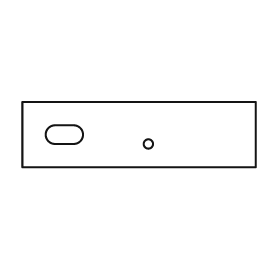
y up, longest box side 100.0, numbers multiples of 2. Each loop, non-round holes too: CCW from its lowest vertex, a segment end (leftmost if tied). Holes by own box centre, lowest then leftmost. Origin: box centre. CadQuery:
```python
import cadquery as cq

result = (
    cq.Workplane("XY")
    .moveTo(-50.0, -14.0)
    .lineTo(50.0, -14.0)
    .lineTo(50.0, 14.0)
    .lineTo(-50.0, 14.0)
    .close()
    .moveTo(4.0, -4.0)
    .circle(2.0)
    .moveTo(-36.0, -4.0)
    .lineTo(-28.0, -4.0)
    .threePointArc((-24.0, 0.0), (-28.0, 4.0))
    .lineTo(-36.0, 4.0)
    .threePointArc((-40.0, 0.0), (-36.0, -4.0))
    .close()
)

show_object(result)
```